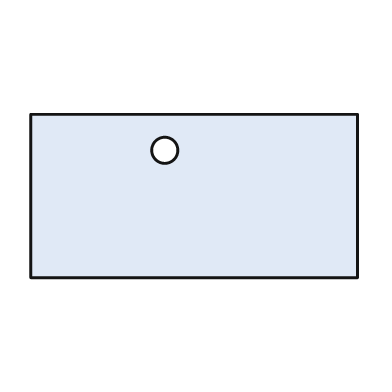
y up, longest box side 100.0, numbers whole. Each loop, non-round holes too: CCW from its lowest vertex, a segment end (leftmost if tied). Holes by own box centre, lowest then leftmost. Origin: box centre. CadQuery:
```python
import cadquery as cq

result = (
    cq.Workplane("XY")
    .moveTo(-50.0, -25.0)
    .lineTo(50.0, -25.0)
    .lineTo(50.0, 25.0)
    .lineTo(-50.0, 25.0)
    .close()
    .moveTo(-9.0, 14.0)
    .circle(4.0)
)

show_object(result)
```